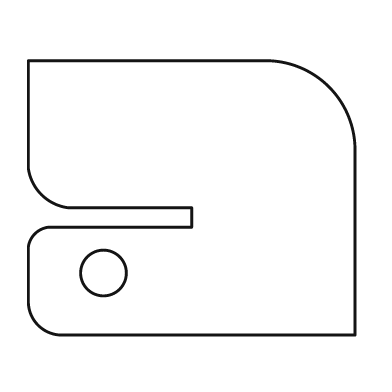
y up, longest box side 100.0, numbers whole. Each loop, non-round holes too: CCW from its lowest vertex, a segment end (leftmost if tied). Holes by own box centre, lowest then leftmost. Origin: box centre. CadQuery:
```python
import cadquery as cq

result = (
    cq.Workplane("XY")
    .moveTo(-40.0, -42.0)
    .lineTo(50.0, -42.0)
    .lineTo(50.0, 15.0)
    .threePointArc((42.0, 34.0), (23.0, 42.0))
    .lineTo(-50.0, 42.0)
    .lineTo(-50.0, 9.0)
    .threePointArc((-46.0, 1.0), (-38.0, -3.0))
    .lineTo(0.0, -3.0)
    .lineTo(0.0, -9.0)
    .lineTo(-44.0, -9.0)
    .threePointArc((-48.0, -11.0), (-50.0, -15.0))
    .lineTo(-50.0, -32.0)
    .threePointArc((-47.0, -39.0), (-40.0, -42.0))
    .close()
    .moveTo(-27.0, -23.0)
    .circle(7.0)
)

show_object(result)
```